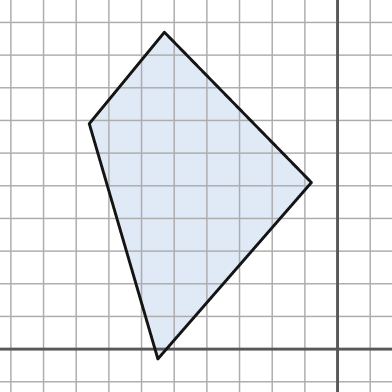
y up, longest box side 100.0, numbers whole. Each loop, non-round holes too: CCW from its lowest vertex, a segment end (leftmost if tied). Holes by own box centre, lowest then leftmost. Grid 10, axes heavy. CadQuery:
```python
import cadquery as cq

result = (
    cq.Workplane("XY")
    .moveTo(-55.0, -3.0)
    .lineTo(-8.0, 51.0)
    .lineTo(-53.0, 97.0)
    .lineTo(-76.0, 69.0)
    .close()
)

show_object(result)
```